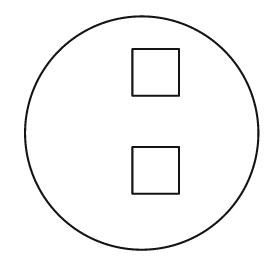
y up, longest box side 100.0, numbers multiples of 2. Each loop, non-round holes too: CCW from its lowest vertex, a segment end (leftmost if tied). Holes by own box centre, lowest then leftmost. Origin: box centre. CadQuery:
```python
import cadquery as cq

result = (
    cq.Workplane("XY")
    .moveTo(0.0, 0.0)
    .circle(50.0)
    .moveTo(-4.0, -26.0)
    .lineTo(16.0, -26.0)
    .lineTo(16.0, -6.0)
    .lineTo(-4.0, -6.0)
    .close()
    .moveTo(-4.0, 16.0)
    .lineTo(16.0, 16.0)
    .lineTo(16.0, 36.0)
    .lineTo(-4.0, 36.0)
    .close()
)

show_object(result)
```